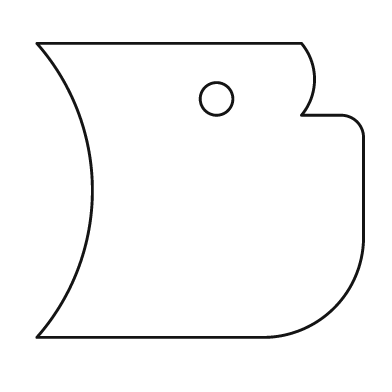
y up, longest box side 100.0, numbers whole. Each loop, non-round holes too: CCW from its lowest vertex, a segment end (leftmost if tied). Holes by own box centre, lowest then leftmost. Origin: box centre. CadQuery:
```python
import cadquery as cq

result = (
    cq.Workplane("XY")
    .moveTo(-50.0, -45.0)
    .lineTo(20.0, -45.0)
    .threePointArc((41.0, -36.0), (50.0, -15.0))
    .lineTo(50.0, 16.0)
    .threePointArc((48.0, 21.0), (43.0, 23.0))
    .lineTo(31.0, 23.0)
    .threePointArc((35.0, 34.0), (31.0, 45.0))
    .lineTo(-50.0, 45.0)
    .threePointArc((-33.0, 0.0), (-50.0, -45.0))
    .close()
    .moveTo(5.0, 28.0)
    .circle(5.0)
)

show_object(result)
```